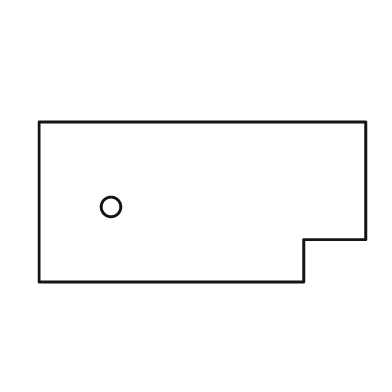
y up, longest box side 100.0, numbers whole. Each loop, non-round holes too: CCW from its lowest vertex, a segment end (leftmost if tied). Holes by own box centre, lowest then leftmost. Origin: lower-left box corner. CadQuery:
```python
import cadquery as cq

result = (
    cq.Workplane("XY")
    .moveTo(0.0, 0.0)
    .lineTo(81.0, 0.0)
    .lineTo(81.0, 13.0)
    .lineTo(100.0, 13.0)
    .lineTo(100.0, 49.0)
    .lineTo(0.0, 49.0)
    .close()
    .moveTo(22.0, 23.0)
    .circle(3.0)
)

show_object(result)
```